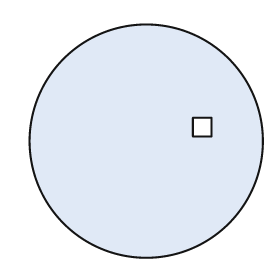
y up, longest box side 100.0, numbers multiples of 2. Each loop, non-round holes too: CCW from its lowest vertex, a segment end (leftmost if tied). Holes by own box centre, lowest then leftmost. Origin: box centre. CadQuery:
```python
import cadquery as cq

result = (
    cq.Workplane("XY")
    .moveTo(0.0, 0.0)
    .circle(50.0)
    .moveTo(20.0, 2.0)
    .lineTo(28.0, 2.0)
    .lineTo(28.0, 10.0)
    .lineTo(20.0, 10.0)
    .close()
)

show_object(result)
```